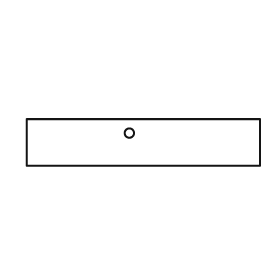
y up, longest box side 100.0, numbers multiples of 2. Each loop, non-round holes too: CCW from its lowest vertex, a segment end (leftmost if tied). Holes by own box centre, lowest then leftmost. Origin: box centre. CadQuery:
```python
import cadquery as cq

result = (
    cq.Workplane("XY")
    .moveTo(-50.0, -10.0)
    .lineTo(50.0, -10.0)
    .lineTo(50.0, 10.0)
    .lineTo(-50.0, 10.0)
    .close()
    .moveTo(-6.0, 4.0)
    .circle(2.0)
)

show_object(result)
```